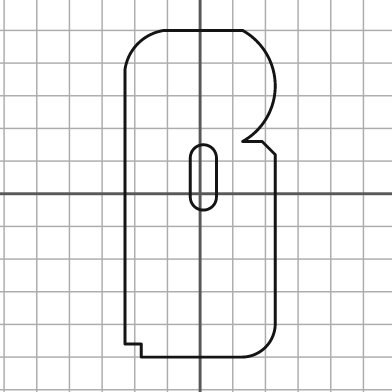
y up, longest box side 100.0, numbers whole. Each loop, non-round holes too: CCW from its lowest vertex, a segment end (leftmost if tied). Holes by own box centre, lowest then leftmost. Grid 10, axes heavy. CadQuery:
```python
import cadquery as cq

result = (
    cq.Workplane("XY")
    .moveTo(-18.0, -50.0)
    .lineTo(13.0, -50.0)
    .threePointArc((20.0, -47.0), (23.0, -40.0))
    .lineTo(23.0, 12.0)
    .lineTo(19.0, 16.0)
    .lineTo(13.0, 16.0)
    .threePointArc((23.0, 33.0), (13.0, 50.0))
    .lineTo(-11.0, 50.0)
    .threePointArc((-19.0, 46.0), (-23.0, 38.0))
    .lineTo(-23.0, -46.0)
    .lineTo(-18.0, -46.0)
    .close()
    .moveTo(-3.0, -1.0)
    .threePointArc((1.0, -5.0), (5.0, -1.0))
    .lineTo(5.0, 11.0)
    .threePointArc((1.0, 15.0), (-3.0, 11.0))
    .close()
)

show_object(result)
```